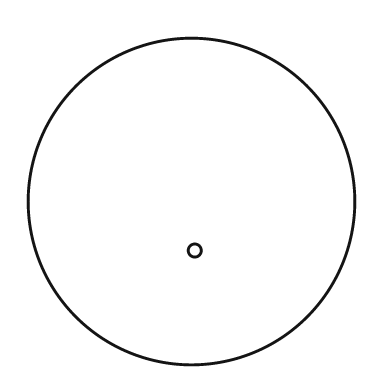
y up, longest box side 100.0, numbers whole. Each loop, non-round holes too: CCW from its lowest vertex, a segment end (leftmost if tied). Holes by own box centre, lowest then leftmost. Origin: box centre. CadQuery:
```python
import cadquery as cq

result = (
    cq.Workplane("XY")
    .moveTo(0.0, 0.0)
    .circle(50.0)
    .moveTo(1.0, -15.0)
    .circle(2.0)
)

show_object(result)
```